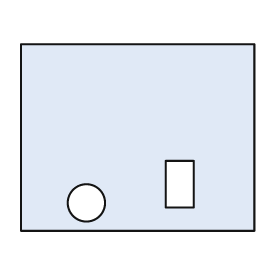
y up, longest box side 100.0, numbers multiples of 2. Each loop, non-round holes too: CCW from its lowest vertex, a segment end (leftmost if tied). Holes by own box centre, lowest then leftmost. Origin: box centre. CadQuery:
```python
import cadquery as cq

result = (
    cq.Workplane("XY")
    .moveTo(-50.0, -40.0)
    .lineTo(50.0, -40.0)
    .lineTo(50.0, 40.0)
    .lineTo(-50.0, 40.0)
    .close()
    .moveTo(-22.0, -28.0)
    .circle(8.0)
    .moveTo(12.0, -30.0)
    .lineTo(24.0, -30.0)
    .lineTo(24.0, -10.0)
    .lineTo(12.0, -10.0)
    .close()
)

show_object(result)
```